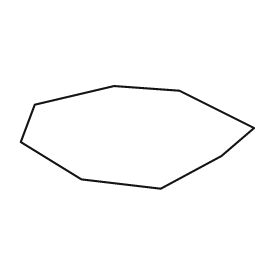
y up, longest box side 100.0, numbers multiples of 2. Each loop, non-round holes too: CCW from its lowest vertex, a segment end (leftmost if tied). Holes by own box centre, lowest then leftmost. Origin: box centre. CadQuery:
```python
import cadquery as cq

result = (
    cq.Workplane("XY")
    .moveTo(10.0, -22.0)
    .lineTo(36.0, -8.0)
    .lineTo(50.0, 4.0)
    .lineTo(18.0, 20.0)
    .lineTo(-10.0, 22.0)
    .lineTo(-44.0, 14.0)
    .lineTo(-50.0, -2.0)
    .lineTo(-24.0, -18.0)
    .close()
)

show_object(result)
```